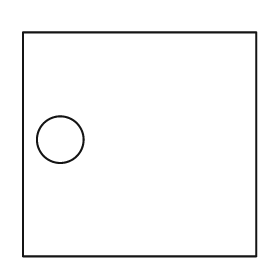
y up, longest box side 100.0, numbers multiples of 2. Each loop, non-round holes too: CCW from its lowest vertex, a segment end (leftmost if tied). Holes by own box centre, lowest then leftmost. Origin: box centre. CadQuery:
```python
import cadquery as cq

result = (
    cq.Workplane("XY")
    .moveTo(-50.0, -48.0)
    .lineTo(50.0, -48.0)
    .lineTo(50.0, 48.0)
    .lineTo(-50.0, 48.0)
    .close()
    .moveTo(-34.0, 2.0)
    .circle(10.0)
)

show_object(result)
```